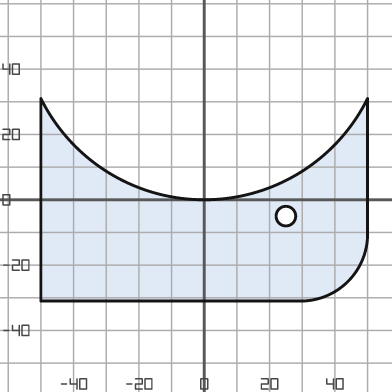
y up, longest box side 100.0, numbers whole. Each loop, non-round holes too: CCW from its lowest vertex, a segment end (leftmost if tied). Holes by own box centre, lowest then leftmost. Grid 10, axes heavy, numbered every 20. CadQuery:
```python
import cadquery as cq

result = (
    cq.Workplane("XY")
    .moveTo(-50.0, -31.0)
    .lineTo(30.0, -31.0)
    .threePointArc((44.0, -25.0), (50.0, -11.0))
    .lineTo(50.0, 31.0)
    .threePointArc((0.0, 0.0), (-50.0, 31.0))
    .close()
    .moveTo(25.0, -5.0)
    .circle(3.0)
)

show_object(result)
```